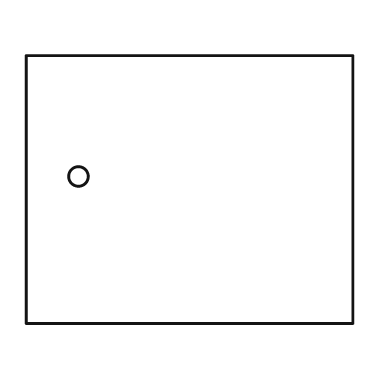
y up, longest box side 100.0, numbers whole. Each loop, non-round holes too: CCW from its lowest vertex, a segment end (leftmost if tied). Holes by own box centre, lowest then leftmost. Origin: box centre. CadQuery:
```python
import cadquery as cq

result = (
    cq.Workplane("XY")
    .moveTo(-50.0, -41.0)
    .lineTo(50.0, -41.0)
    .lineTo(50.0, 41.0)
    .lineTo(-50.0, 41.0)
    .close()
    .moveTo(-34.0, 4.0)
    .circle(3.0)
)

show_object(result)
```